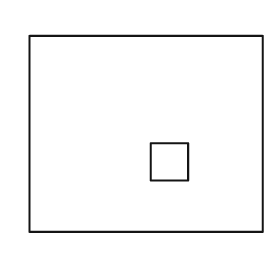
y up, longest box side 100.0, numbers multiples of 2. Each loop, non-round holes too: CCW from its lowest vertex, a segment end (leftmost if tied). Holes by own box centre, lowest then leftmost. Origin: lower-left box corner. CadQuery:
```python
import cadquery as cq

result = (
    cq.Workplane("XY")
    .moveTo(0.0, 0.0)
    .lineTo(100.0, 0.0)
    .lineTo(100.0, 84.0)
    .lineTo(0.0, 84.0)
    .close()
    .moveTo(52.0, 22.0)
    .lineTo(68.0, 22.0)
    .lineTo(68.0, 38.0)
    .lineTo(52.0, 38.0)
    .close()
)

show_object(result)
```